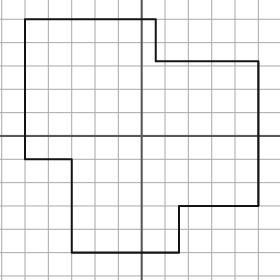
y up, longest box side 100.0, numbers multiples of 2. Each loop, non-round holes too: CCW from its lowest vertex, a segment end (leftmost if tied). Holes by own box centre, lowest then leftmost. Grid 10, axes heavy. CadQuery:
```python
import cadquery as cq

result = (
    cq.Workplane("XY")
    .moveTo(-30.0, -50.0)
    .lineTo(16.0, -50.0)
    .lineTo(16.0, -30.0)
    .lineTo(50.0, -30.0)
    .lineTo(50.0, 32.0)
    .lineTo(6.0, 32.0)
    .lineTo(6.0, 50.0)
    .lineTo(-50.0, 50.0)
    .lineTo(-50.0, -10.0)
    .lineTo(-30.0, -10.0)
    .close()
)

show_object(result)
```